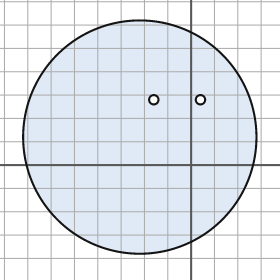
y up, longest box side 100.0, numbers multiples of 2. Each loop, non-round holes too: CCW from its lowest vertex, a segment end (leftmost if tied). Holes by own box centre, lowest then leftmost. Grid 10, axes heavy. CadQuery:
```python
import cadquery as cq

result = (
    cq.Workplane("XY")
    .moveTo(-22.0, 12.0)
    .circle(50.0)
    .moveTo(-16.0, 28.0)
    .circle(2.0)
    .moveTo(4.0, 28.0)
    .circle(2.0)
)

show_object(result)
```